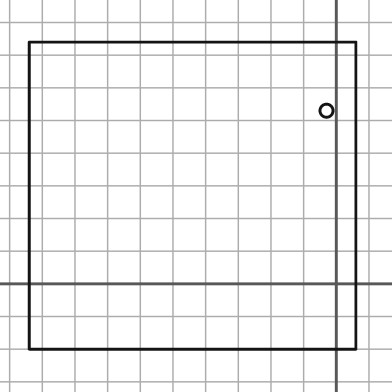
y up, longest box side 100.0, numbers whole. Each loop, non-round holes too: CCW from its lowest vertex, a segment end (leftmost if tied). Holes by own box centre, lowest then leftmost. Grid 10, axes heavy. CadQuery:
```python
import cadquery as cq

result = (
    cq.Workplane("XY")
    .moveTo(-94.0, -20.0)
    .lineTo(6.0, -20.0)
    .lineTo(6.0, 74.0)
    .lineTo(-94.0, 74.0)
    .close()
    .moveTo(-3.0, 53.0)
    .circle(2.0)
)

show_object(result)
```